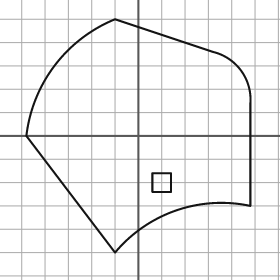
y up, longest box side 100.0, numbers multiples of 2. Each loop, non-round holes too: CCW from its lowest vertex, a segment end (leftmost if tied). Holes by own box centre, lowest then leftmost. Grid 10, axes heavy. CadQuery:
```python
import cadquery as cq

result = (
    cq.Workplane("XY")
    .moveTo(-10.0, -50.0)
    .threePointArc((16.0, -32.0), (48.0, -30.0))
    .lineTo(48.0, 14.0)
    .threePointArc((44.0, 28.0), (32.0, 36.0))
    .lineTo(-10.0, 50.0)
    .threePointArc((-36.0, 30.0), (-48.0, 0.0))
    .close()
    .moveTo(6.0, -24.0)
    .lineTo(14.0, -24.0)
    .lineTo(14.0, -16.0)
    .lineTo(6.0, -16.0)
    .close()
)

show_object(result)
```